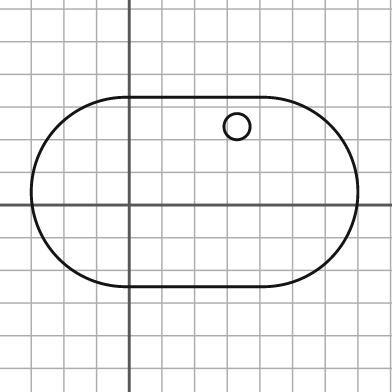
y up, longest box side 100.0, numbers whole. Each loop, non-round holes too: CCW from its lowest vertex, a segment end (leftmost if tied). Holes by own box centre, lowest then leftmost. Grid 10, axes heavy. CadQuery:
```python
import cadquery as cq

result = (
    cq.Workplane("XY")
    .moveTo(-1.0, -25.0)
    .lineTo(41.0, -25.0)
    .threePointArc((70.0, 4.0), (41.0, 33.0))
    .lineTo(-1.0, 33.0)
    .threePointArc((-30.0, 4.0), (-1.0, -25.0))
    .close()
    .moveTo(33.0, 24.0)
    .circle(4.0)
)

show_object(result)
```